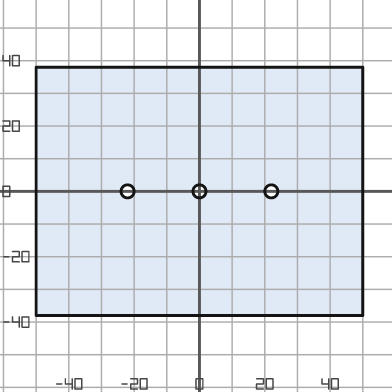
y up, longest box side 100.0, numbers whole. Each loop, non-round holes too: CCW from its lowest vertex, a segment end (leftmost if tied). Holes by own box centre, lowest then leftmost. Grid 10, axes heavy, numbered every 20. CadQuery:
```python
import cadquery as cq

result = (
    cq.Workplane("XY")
    .moveTo(-50.0, -38.0)
    .lineTo(50.0, -38.0)
    .lineTo(50.0, 38.0)
    .lineTo(-50.0, 38.0)
    .close()
    .moveTo(-22.0, 0.0)
    .circle(2.0)
    .moveTo(0.0, 0.0)
    .circle(2.0)
    .moveTo(22.0, 0.0)
    .circle(2.0)
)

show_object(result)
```